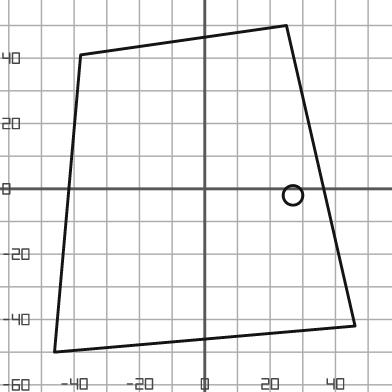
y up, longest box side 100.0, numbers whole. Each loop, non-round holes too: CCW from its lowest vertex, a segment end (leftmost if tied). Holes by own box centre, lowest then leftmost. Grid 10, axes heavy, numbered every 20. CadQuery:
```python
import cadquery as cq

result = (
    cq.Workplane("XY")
    .moveTo(-46.0, -50.0)
    .lineTo(46.0, -42.0)
    .lineTo(25.0, 50.0)
    .lineTo(-38.0, 41.0)
    .close()
    .moveTo(27.0, -2.0)
    .circle(3.0)
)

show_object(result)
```